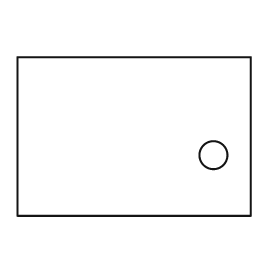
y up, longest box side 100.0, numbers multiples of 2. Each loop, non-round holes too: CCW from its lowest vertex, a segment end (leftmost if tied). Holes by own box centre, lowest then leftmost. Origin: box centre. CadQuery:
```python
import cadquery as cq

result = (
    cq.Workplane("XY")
    .moveTo(-50.0, -34.0)
    .lineTo(50.0, -34.0)
    .lineTo(50.0, 34.0)
    .lineTo(-50.0, 34.0)
    .close()
    .moveTo(34.0, -8.0)
    .circle(6.0)
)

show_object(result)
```